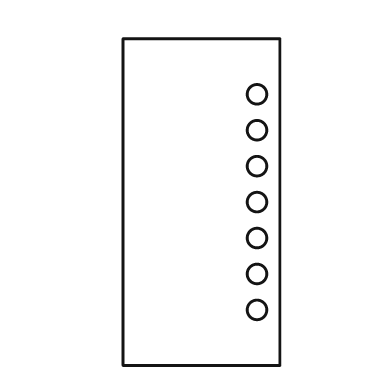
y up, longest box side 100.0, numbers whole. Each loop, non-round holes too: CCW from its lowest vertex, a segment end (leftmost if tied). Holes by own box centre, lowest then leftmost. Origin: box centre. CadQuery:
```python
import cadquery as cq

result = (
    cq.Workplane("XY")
    .moveTo(-24.0, -50.0)
    .lineTo(24.0, -50.0)
    .lineTo(24.0, 50.0)
    .lineTo(-24.0, 50.0)
    .close()
    .moveTo(17.0, -33.0)
    .circle(3.0)
    .moveTo(17.0, -22.0)
    .circle(3.0)
    .moveTo(17.0, -11.0)
    .circle(3.0)
    .moveTo(17.0, 0.0)
    .circle(3.0)
    .moveTo(17.0, 11.0)
    .circle(3.0)
    .moveTo(17.0, 22.0)
    .circle(3.0)
    .moveTo(17.0, 33.0)
    .circle(3.0)
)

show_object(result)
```